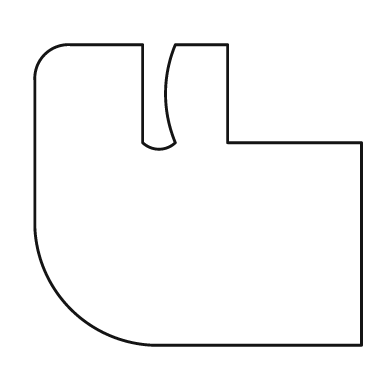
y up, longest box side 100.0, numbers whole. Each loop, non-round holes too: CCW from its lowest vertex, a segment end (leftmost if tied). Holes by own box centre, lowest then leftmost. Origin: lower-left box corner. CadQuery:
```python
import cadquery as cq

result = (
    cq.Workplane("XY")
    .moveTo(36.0, 0.0)
    .lineTo(100.0, 0.0)
    .lineTo(100.0, 62.0)
    .lineTo(59.0, 62.0)
    .lineTo(59.0, 92.0)
    .lineTo(43.0, 92.0)
    .threePointArc((40.0, 77.0), (43.0, 62.0))
    .threePointArc((38.0, 60.0), (33.0, 62.0))
    .lineTo(33.0, 92.0)
    .lineTo(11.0, 92.0)
    .threePointArc((3.0, 89.0), (0.0, 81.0))
    .lineTo(0.0, 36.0)
    .threePointArc((11.0, 11.0), (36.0, 0.0))
    .close()
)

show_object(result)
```